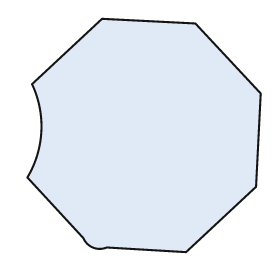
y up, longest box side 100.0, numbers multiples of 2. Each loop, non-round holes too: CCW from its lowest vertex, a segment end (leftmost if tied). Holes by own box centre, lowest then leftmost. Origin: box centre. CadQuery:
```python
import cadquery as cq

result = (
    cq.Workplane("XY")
    .moveTo(18.0, -50.0)
    .lineTo(48.0, -22.0)
    .lineTo(50.0, 18.0)
    .lineTo(22.0, 48.0)
    .lineTo(-18.0, 50.0)
    .lineTo(-48.0, 22.0)
    .threePointArc((-44.0, 2.0), (-50.0, -18.0))
    .lineTo(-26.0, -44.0)
    .threePointArc((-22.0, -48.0), (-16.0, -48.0))
    .close()
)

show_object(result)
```